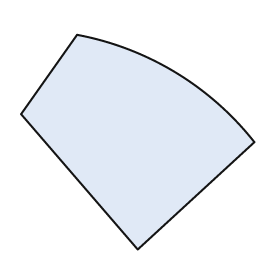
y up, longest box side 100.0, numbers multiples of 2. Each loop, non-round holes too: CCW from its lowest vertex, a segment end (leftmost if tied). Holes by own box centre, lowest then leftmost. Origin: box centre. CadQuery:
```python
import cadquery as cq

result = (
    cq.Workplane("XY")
    .moveTo(0.0, -46.0)
    .lineTo(50.0, 0.0)
    .threePointArc((16.0, 30.0), (-26.0, 46.0))
    .lineTo(-50.0, 12.0)
    .close()
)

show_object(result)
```